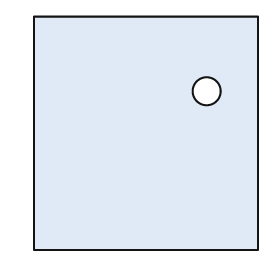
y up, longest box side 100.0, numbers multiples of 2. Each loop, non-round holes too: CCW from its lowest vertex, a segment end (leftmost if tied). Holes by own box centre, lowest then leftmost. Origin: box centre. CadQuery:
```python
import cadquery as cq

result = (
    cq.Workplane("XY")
    .moveTo(-48.0, -50.0)
    .lineTo(48.0, -50.0)
    .lineTo(48.0, 50.0)
    .lineTo(-48.0, 50.0)
    .close()
    .moveTo(26.0, 18.0)
    .circle(6.0)
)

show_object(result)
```